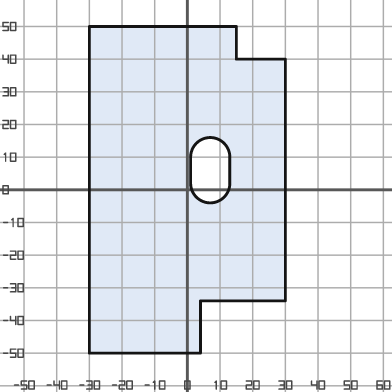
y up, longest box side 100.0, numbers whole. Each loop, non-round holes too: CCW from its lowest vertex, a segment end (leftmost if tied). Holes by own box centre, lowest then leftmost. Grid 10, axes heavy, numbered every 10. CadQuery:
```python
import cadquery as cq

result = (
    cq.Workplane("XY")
    .moveTo(-30.0, -50.0)
    .lineTo(4.0, -50.0)
    .lineTo(4.0, -34.0)
    .lineTo(30.0, -34.0)
    .lineTo(30.0, 40.0)
    .lineTo(15.0, 40.0)
    .lineTo(15.0, 50.0)
    .lineTo(-30.0, 50.0)
    .close()
    .moveTo(1.0, 2.0)
    .threePointArc((7.0, -4.0), (13.0, 2.0))
    .lineTo(13.0, 10.0)
    .threePointArc((7.0, 16.0), (1.0, 10.0))
    .close()
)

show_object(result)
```